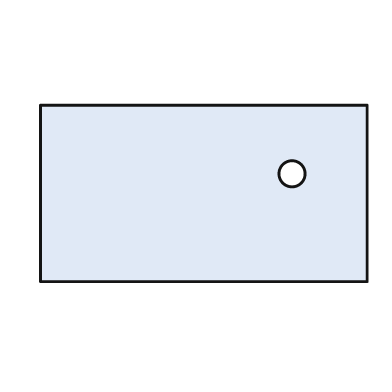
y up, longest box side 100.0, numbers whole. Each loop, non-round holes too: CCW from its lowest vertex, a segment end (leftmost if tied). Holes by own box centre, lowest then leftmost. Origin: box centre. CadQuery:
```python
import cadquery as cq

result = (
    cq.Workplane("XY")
    .moveTo(-50.0, -27.0)
    .lineTo(50.0, -27.0)
    .lineTo(50.0, 27.0)
    .lineTo(-50.0, 27.0)
    .close()
    .moveTo(27.0, 6.0)
    .circle(4.0)
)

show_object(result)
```